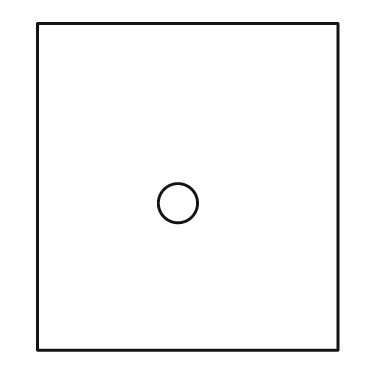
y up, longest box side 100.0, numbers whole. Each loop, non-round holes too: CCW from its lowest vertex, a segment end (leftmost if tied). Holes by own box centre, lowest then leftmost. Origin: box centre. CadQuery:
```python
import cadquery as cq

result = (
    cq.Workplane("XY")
    .moveTo(-46.0, -50.0)
    .lineTo(46.0, -50.0)
    .lineTo(46.0, 50.0)
    .lineTo(-46.0, 50.0)
    .close()
    .moveTo(-3.0, -5.0)
    .circle(6.0)
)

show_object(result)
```